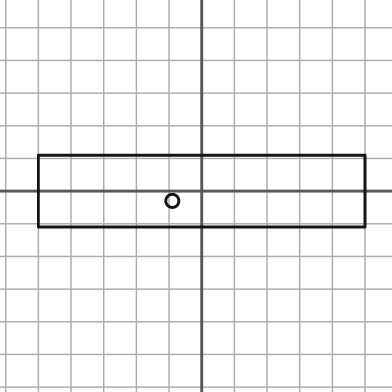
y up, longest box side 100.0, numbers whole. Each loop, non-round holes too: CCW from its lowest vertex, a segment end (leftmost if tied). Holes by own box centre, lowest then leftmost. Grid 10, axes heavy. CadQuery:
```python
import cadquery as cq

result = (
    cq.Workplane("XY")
    .moveTo(-50.0, -11.0)
    .lineTo(50.0, -11.0)
    .lineTo(50.0, 11.0)
    .lineTo(-50.0, 11.0)
    .close()
    .moveTo(-9.0, -3.0)
    .circle(2.0)
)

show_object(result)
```